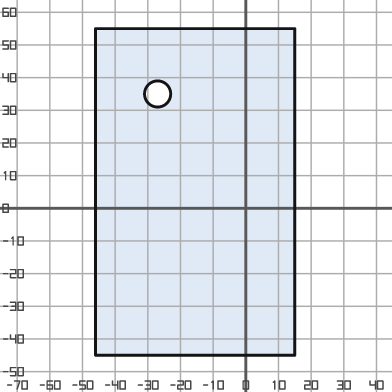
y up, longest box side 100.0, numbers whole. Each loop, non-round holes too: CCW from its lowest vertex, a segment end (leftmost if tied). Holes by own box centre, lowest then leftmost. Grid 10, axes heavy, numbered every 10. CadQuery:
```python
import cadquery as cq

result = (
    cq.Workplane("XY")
    .moveTo(-46.0, -45.0)
    .lineTo(15.0, -45.0)
    .lineTo(15.0, 55.0)
    .lineTo(-46.0, 55.0)
    .close()
    .moveTo(-27.0, 35.0)
    .circle(4.0)
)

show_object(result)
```